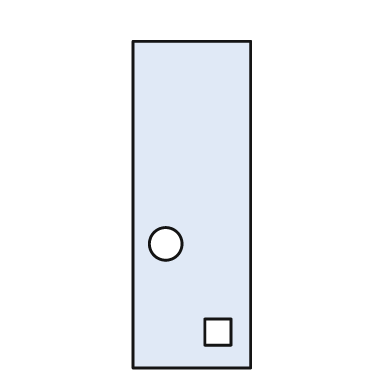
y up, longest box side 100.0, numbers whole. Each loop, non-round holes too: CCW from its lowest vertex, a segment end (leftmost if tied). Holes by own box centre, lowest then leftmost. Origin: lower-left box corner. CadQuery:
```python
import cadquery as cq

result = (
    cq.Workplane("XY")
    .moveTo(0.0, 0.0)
    .lineTo(36.0, 0.0)
    .lineTo(36.0, 100.0)
    .lineTo(0.0, 100.0)
    .close()
    .moveTo(22.0, 7.0)
    .lineTo(30.0, 7.0)
    .lineTo(30.0, 15.0)
    .lineTo(22.0, 15.0)
    .close()
    .moveTo(10.0, 38.0)
    .circle(5.0)
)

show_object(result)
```